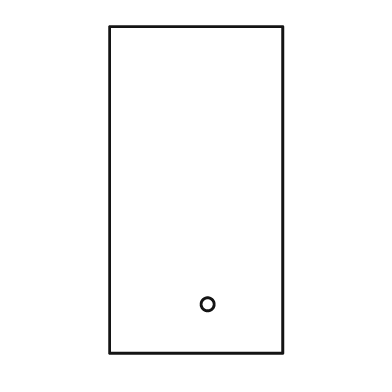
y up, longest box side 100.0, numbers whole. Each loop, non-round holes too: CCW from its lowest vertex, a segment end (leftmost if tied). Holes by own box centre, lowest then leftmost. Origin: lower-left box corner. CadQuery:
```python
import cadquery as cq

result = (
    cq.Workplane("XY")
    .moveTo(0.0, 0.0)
    .lineTo(53.0, 0.0)
    .lineTo(53.0, 100.0)
    .lineTo(0.0, 100.0)
    .close()
    .moveTo(30.0, 15.0)
    .circle(2.0)
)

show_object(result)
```